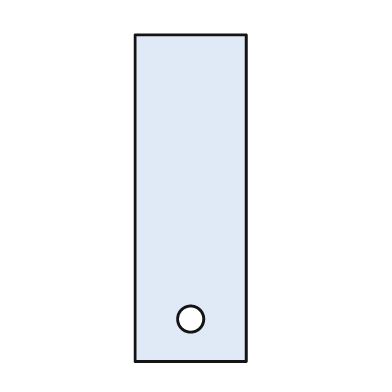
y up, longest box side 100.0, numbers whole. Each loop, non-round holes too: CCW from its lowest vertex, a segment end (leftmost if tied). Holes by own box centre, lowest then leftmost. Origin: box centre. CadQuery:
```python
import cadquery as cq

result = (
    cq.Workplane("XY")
    .moveTo(-17.0, -50.0)
    .lineTo(17.0, -50.0)
    .lineTo(17.0, 50.0)
    .lineTo(-17.0, 50.0)
    .close()
    .moveTo(0.0, -37.0)
    .circle(4.0)
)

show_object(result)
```